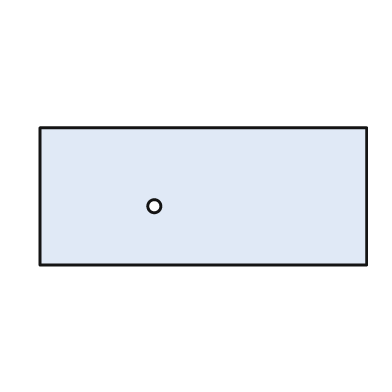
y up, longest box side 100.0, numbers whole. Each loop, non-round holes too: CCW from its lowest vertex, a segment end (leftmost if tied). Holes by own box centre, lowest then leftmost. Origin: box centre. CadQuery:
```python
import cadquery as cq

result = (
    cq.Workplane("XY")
    .moveTo(-50.0, -21.0)
    .lineTo(50.0, -21.0)
    .lineTo(50.0, 21.0)
    .lineTo(-50.0, 21.0)
    .close()
    .moveTo(-15.0, -3.0)
    .circle(2.0)
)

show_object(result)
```